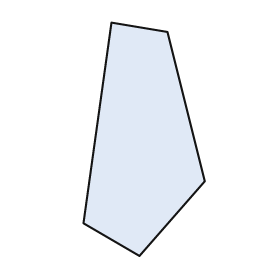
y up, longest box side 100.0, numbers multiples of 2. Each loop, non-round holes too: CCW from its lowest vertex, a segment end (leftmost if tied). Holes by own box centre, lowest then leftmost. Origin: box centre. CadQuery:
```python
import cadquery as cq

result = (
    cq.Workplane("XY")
    .moveTo(-2.0, -50.0)
    .lineTo(26.0, -18.0)
    .lineTo(10.0, 46.0)
    .lineTo(-14.0, 50.0)
    .lineTo(-26.0, -36.0)
    .close()
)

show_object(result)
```